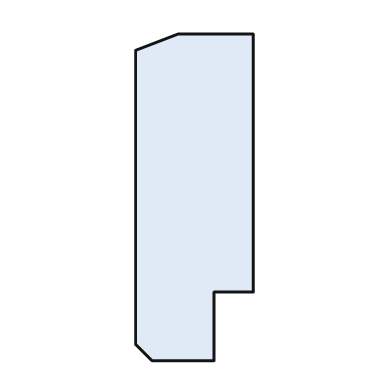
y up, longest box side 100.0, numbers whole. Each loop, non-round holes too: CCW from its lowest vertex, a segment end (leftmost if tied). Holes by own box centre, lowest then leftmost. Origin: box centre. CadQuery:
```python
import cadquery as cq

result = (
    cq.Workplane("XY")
    .moveTo(-13.0, -50.0)
    .lineTo(6.0, -50.0)
    .lineTo(6.0, -29.0)
    .lineTo(18.0, -29.0)
    .lineTo(18.0, 50.0)
    .lineTo(-5.0, 50.0)
    .lineTo(-18.0, 45.0)
    .lineTo(-18.0, -45.0)
    .close()
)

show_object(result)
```